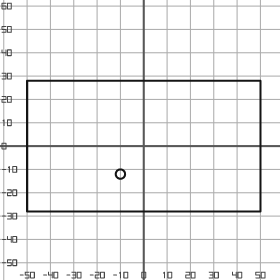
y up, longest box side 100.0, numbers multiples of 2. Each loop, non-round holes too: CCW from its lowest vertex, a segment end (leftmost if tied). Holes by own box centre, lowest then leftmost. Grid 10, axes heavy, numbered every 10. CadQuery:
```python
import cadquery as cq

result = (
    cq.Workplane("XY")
    .moveTo(-50.0, -28.0)
    .lineTo(50.0, -28.0)
    .lineTo(50.0, 28.0)
    .lineTo(-50.0, 28.0)
    .close()
    .moveTo(-10.0, -12.0)
    .circle(2.0)
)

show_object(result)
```